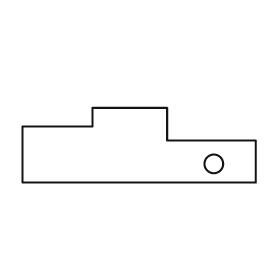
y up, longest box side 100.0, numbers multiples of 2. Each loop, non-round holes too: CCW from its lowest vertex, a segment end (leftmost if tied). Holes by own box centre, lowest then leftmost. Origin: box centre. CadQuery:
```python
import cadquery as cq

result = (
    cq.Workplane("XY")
    .moveTo(-50.0, -16.0)
    .lineTo(50.0, -16.0)
    .lineTo(50.0, 2.0)
    .lineTo(12.0, 2.0)
    .lineTo(12.0, 16.0)
    .lineTo(-20.0, 16.0)
    .lineTo(-20.0, 8.0)
    .lineTo(-50.0, 8.0)
    .close()
    .moveTo(32.0, -8.0)
    .circle(4.0)
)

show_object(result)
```